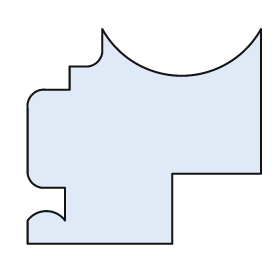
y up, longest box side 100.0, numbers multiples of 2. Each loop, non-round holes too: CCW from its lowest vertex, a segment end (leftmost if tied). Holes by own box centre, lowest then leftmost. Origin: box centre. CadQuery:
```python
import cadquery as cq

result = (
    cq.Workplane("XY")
    .moveTo(-50.0, -46.0)
    .lineTo(12.0, -46.0)
    .lineTo(12.0, -16.0)
    .lineTo(50.0, -16.0)
    .lineTo(50.0, 46.0)
    .threePointArc((16.0, 26.0), (-18.0, 46.0))
    .lineTo(-18.0, 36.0)
    .threePointArc((-20.0, 32.0), (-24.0, 30.0))
    .lineTo(-32.0, 30.0)
    .lineTo(-32.0, 20.0)
    .lineTo(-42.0, 20.0)
    .threePointArc((-48.0, 18.0), (-50.0, 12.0))
    .lineTo(-50.0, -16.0)
    .threePointArc((-48.0, -20.0), (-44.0, -22.0))
    .lineTo(-34.0, -22.0)
    .lineTo(-34.0, -36.0)
    .threePointArc((-42.0, -32.0), (-50.0, -36.0))
    .close()
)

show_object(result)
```